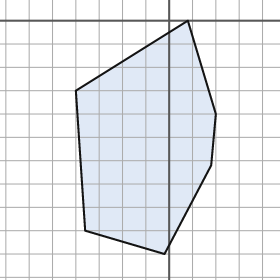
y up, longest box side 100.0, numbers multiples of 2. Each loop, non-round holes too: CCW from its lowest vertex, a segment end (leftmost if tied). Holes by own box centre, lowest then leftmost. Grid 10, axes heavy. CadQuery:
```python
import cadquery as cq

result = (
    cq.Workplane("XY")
    .moveTo(-2.0, -100.0)
    .lineTo(18.0, -62.0)
    .lineTo(20.0, -40.0)
    .lineTo(8.0, 0.0)
    .lineTo(-40.0, -30.0)
    .lineTo(-36.0, -90.0)
    .close()
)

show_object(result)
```